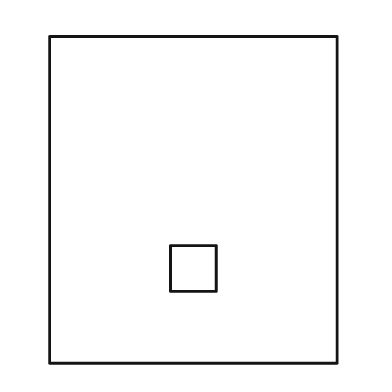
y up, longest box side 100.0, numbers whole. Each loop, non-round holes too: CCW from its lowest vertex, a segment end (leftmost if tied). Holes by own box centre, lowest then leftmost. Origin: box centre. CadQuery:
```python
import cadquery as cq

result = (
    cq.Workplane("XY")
    .moveTo(-44.0, -50.0)
    .lineTo(44.0, -50.0)
    .lineTo(44.0, 50.0)
    .lineTo(-44.0, 50.0)
    .close()
    .moveTo(-7.0, -28.0)
    .lineTo(7.0, -28.0)
    .lineTo(7.0, -14.0)
    .lineTo(-7.0, -14.0)
    .close()
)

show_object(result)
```